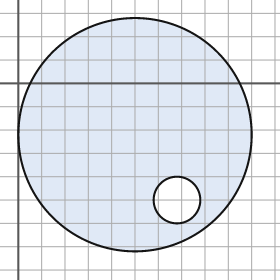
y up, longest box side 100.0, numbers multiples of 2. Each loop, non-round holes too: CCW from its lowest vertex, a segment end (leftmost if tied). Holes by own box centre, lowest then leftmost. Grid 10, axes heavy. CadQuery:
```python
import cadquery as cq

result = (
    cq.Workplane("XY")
    .moveTo(50.0, -22.0)
    .circle(50.0)
    .moveTo(68.0, -50.0)
    .circle(10.0)
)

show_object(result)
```